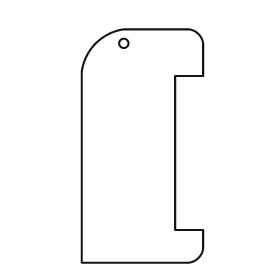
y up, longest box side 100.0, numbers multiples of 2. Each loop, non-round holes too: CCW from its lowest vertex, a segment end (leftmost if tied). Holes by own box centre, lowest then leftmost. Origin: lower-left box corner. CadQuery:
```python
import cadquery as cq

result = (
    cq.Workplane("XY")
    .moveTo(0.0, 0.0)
    .lineTo(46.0, 0.0)
    .threePointArc((50.0, 2.0), (52.0, 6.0))
    .lineTo(52.0, 14.0)
    .lineTo(40.0, 14.0)
    .lineTo(40.0, 80.0)
    .lineTo(52.0, 80.0)
    .lineTo(52.0, 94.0)
    .threePointArc((50.0, 98.0), (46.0, 100.0))
    .lineTo(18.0, 100.0)
    .threePointArc((6.0, 94.0), (0.0, 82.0))
    .close()
    .moveTo(18.0, 94.0)
    .circle(2.0)
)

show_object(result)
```